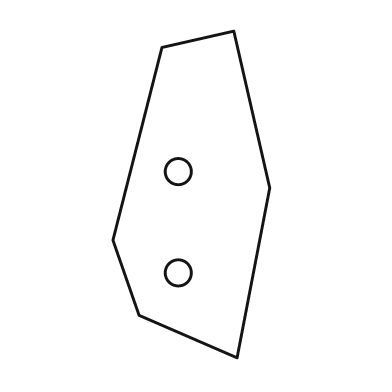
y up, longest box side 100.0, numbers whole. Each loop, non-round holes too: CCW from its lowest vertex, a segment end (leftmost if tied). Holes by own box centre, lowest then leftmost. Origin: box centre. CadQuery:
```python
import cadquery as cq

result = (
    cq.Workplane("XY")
    .moveTo(14.0, -50.0)
    .lineTo(24.0, 2.0)
    .lineTo(13.0, 50.0)
    .lineTo(-9.0, 45.0)
    .lineTo(-24.0, -14.0)
    .lineTo(-16.0, -37.0)
    .close()
    .moveTo(-4.0, -24.0)
    .circle(4.0)
    .moveTo(-4.0, 7.0)
    .circle(4.0)
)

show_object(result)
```